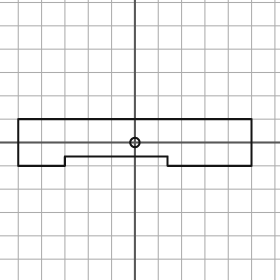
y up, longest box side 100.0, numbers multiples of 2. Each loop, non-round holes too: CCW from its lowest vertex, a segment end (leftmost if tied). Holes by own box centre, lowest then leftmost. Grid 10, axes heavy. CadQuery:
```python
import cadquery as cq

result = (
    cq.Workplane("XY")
    .moveTo(-50.0, -10.0)
    .lineTo(-30.0, -10.0)
    .lineTo(-30.0, -6.0)
    .lineTo(14.0, -6.0)
    .lineTo(14.0, -10.0)
    .lineTo(50.0, -10.0)
    .lineTo(50.0, 10.0)
    .lineTo(-50.0, 10.0)
    .close()
    .moveTo(0.0, 0.0)
    .circle(2.0)
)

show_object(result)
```